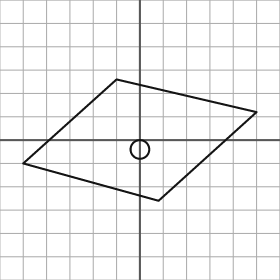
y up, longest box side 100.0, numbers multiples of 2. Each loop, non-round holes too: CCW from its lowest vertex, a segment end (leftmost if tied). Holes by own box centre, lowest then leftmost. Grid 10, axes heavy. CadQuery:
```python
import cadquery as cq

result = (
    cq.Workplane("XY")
    .moveTo(8.0, -26.0)
    .lineTo(50.0, 12.0)
    .lineTo(-10.0, 26.0)
    .lineTo(-50.0, -10.0)
    .close()
    .moveTo(0.0, -4.0)
    .circle(4.0)
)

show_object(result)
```